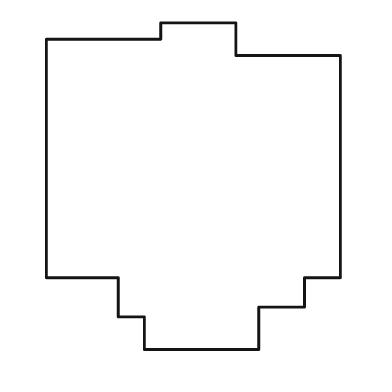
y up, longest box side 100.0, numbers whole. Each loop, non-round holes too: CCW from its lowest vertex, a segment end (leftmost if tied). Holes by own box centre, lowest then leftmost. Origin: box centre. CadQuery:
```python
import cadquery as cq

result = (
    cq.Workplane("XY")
    .moveTo(-15.0, -50.0)
    .lineTo(20.0, -50.0)
    .lineTo(20.0, -37.0)
    .lineTo(34.0, -37.0)
    .lineTo(34.0, -28.0)
    .lineTo(45.0, -28.0)
    .lineTo(45.0, 40.0)
    .lineTo(13.0, 40.0)
    .lineTo(13.0, 50.0)
    .lineTo(-10.0, 50.0)
    .lineTo(-10.0, 45.0)
    .lineTo(-45.0, 45.0)
    .lineTo(-45.0, -28.0)
    .lineTo(-23.0, -28.0)
    .lineTo(-23.0, -40.0)
    .lineTo(-15.0, -40.0)
    .close()
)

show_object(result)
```